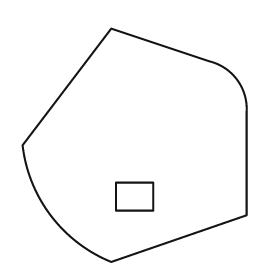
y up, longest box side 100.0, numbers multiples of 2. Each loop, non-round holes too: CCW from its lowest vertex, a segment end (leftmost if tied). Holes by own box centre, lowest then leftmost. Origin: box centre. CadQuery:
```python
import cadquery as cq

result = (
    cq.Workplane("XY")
    .moveTo(-10.0, -50.0)
    .lineTo(48.0, -30.0)
    .lineTo(48.0, 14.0)
    .threePointArc((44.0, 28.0), (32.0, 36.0))
    .lineTo(-10.0, 50.0)
    .lineTo(-48.0, 0.0)
    .threePointArc((-36.0, -30.0), (-10.0, -50.0))
    .close()
    .moveTo(-8.0, -28.0)
    .lineTo(8.0, -28.0)
    .lineTo(8.0, -16.0)
    .lineTo(-8.0, -16.0)
    .close()
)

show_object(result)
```